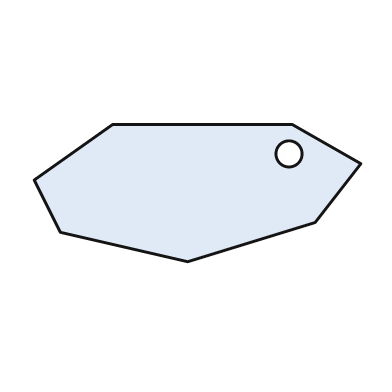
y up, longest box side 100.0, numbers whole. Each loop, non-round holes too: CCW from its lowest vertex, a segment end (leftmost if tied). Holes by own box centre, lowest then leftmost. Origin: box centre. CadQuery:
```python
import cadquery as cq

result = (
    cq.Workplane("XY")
    .moveTo(-3.0, -21.0)
    .lineTo(36.0, -9.0)
    .lineTo(50.0, 9.0)
    .lineTo(29.0, 21.0)
    .lineTo(-26.0, 21.0)
    .lineTo(-50.0, 4.0)
    .lineTo(-42.0, -12.0)
    .close()
    .moveTo(28.0, 12.0)
    .circle(4.0)
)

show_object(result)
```